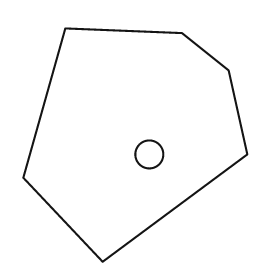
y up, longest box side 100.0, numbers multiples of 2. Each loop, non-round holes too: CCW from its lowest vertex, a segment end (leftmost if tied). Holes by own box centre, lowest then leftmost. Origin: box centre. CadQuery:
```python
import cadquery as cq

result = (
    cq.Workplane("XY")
    .moveTo(-14.0, -50.0)
    .lineTo(48.0, -4.0)
    .lineTo(40.0, 32.0)
    .lineTo(20.0, 48.0)
    .lineTo(-30.0, 50.0)
    .lineTo(-48.0, -14.0)
    .close()
    .moveTo(6.0, -4.0)
    .circle(6.0)
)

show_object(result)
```